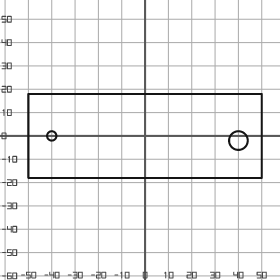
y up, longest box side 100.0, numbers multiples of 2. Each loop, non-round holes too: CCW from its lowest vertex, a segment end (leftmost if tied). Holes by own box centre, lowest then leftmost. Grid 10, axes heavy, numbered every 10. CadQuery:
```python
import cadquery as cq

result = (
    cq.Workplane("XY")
    .moveTo(-50.0, -18.0)
    .lineTo(50.0, -18.0)
    .lineTo(50.0, 18.0)
    .lineTo(-50.0, 18.0)
    .close()
    .moveTo(40.0, -2.0)
    .circle(4.0)
    .moveTo(-40.0, 0.0)
    .circle(2.0)
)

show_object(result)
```